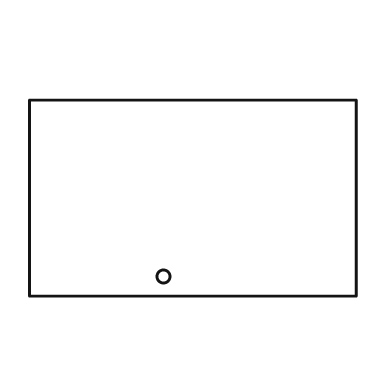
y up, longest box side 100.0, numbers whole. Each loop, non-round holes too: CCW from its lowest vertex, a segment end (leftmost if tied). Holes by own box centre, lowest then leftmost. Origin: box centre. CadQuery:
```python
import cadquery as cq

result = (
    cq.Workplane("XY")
    .moveTo(-50.0, -30.0)
    .lineTo(50.0, -30.0)
    .lineTo(50.0, 30.0)
    .lineTo(-50.0, 30.0)
    .close()
    .moveTo(-9.0, -24.0)
    .circle(2.0)
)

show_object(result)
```